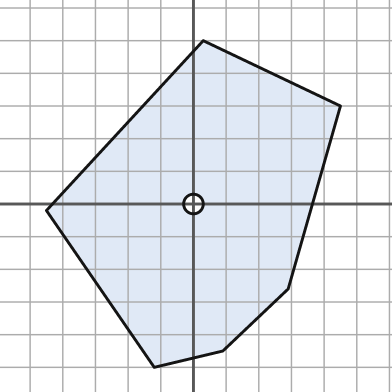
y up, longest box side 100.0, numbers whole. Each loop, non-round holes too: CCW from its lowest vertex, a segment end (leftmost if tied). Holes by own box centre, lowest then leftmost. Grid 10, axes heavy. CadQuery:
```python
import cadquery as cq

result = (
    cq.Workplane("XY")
    .moveTo(-12.0, -50.0)
    .lineTo(9.0, -45.0)
    .lineTo(29.0, -26.0)
    .lineTo(45.0, 30.0)
    .lineTo(3.0, 50.0)
    .lineTo(-45.0, -2.0)
    .close()
    .moveTo(0.0, 0.0)
    .circle(3.0)
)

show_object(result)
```